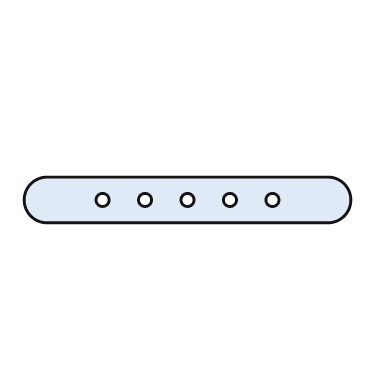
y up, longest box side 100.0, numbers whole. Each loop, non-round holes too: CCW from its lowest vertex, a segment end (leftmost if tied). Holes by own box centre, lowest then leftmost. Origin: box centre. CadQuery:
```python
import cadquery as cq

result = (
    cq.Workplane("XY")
    .moveTo(-43.0, -7.0)
    .lineTo(43.0, -7.0)
    .threePointArc((50.0, 0.0), (43.0, 7.0))
    .lineTo(-43.0, 7.0)
    .threePointArc((-50.0, 0.0), (-43.0, -7.0))
    .close()
    .moveTo(-26.0, 0.0)
    .circle(2.0)
    .moveTo(-13.0, 0.0)
    .circle(2.0)
    .moveTo(0.0, 0.0)
    .circle(2.0)
    .moveTo(13.0, 0.0)
    .circle(2.0)
    .moveTo(26.0, 0.0)
    .circle(2.0)
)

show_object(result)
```